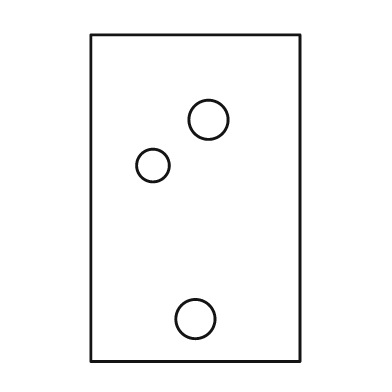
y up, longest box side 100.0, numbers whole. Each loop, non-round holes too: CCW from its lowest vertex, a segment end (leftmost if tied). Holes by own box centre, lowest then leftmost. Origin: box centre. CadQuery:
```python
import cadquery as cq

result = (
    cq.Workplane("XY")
    .moveTo(-32.0, -50.0)
    .lineTo(32.0, -50.0)
    .lineTo(32.0, 50.0)
    .lineTo(-32.0, 50.0)
    .close()
    .moveTo(0.0, -37.0)
    .circle(6.0)
    .moveTo(-13.0, 10.0)
    .circle(5.0)
    .moveTo(4.0, 24.0)
    .circle(6.0)
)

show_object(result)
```